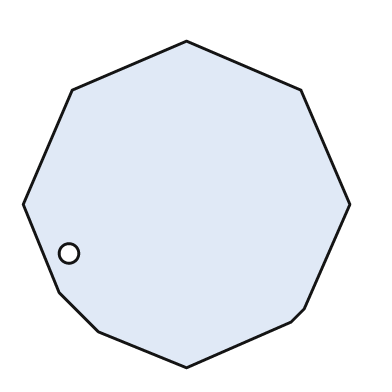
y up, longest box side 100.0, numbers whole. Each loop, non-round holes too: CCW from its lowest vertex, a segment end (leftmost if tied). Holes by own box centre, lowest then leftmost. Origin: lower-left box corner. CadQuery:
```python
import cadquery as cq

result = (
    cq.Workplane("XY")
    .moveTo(50.0, 0.0)
    .lineTo(82.0, 14.0)
    .lineTo(86.0, 18.0)
    .lineTo(100.0, 50.0)
    .lineTo(85.0, 85.0)
    .lineTo(50.0, 100.0)
    .lineTo(15.0, 85.0)
    .lineTo(0.0, 50.0)
    .lineTo(11.0, 23.0)
    .lineTo(23.0, 11.0)
    .close()
    .moveTo(14.0, 35.0)
    .circle(3.0)
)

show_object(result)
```